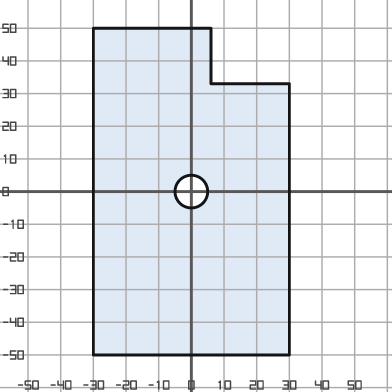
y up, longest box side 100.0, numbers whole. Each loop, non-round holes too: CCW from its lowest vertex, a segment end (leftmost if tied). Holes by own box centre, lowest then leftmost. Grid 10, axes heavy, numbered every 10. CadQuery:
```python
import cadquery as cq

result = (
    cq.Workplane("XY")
    .moveTo(-30.0, -50.0)
    .lineTo(30.0, -50.0)
    .lineTo(30.0, 33.0)
    .lineTo(6.0, 33.0)
    .lineTo(6.0, 50.0)
    .lineTo(-30.0, 50.0)
    .close()
    .moveTo(0.0, 0.0)
    .circle(5.0)
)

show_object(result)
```